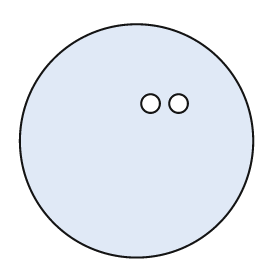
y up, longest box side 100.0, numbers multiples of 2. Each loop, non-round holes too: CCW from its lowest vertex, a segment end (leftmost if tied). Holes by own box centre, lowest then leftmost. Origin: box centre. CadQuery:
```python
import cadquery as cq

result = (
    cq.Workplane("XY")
    .moveTo(0.0, 0.0)
    .circle(50.0)
    .moveTo(6.0, 16.0)
    .circle(4.0)
    .moveTo(18.0, 16.0)
    .circle(4.0)
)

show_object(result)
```